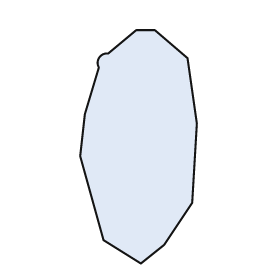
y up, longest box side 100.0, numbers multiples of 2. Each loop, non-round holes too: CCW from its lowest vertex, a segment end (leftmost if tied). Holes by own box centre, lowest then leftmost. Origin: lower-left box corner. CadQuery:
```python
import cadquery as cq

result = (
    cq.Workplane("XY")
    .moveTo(26.0, 0.0)
    .lineTo(36.0, 8.0)
    .lineTo(48.0, 26.0)
    .lineTo(50.0, 60.0)
    .lineTo(46.0, 88.0)
    .lineTo(32.0, 100.0)
    .lineTo(24.0, 100.0)
    .lineTo(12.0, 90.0)
    .threePointArc((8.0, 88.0), (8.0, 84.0))
    .lineTo(2.0, 64.0)
    .lineTo(0.0, 46.0)
    .lineTo(10.0, 10.0)
    .close()
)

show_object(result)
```